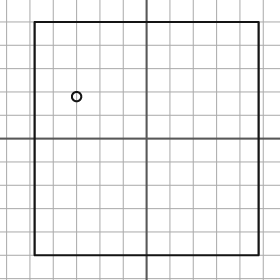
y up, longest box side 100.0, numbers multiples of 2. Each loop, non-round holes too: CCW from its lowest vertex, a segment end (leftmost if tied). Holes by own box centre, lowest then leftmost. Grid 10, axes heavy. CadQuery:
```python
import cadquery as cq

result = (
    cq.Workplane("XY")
    .moveTo(-48.0, -50.0)
    .lineTo(48.0, -50.0)
    .lineTo(48.0, 50.0)
    .lineTo(-48.0, 50.0)
    .close()
    .moveTo(-30.0, 18.0)
    .circle(2.0)
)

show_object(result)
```